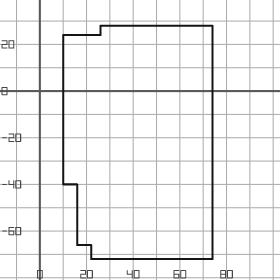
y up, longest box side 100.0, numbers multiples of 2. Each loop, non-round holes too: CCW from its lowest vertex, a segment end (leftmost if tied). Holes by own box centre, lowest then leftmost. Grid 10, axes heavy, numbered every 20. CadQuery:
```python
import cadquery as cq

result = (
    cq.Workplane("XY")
    .moveTo(22.0, -72.0)
    .lineTo(74.0, -72.0)
    .lineTo(74.0, 28.0)
    .lineTo(26.0, 28.0)
    .lineTo(26.0, 24.0)
    .lineTo(10.0, 24.0)
    .lineTo(10.0, -40.0)
    .lineTo(16.0, -40.0)
    .lineTo(16.0, -66.0)
    .lineTo(22.0, -66.0)
    .close()
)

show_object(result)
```